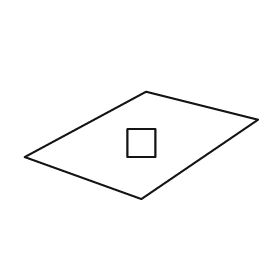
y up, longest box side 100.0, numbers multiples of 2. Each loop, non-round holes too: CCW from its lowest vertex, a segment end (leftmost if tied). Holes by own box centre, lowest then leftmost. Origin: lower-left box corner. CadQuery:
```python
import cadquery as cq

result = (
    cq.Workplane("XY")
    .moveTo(50.0, 0.0)
    .lineTo(100.0, 34.0)
    .lineTo(52.0, 46.0)
    .lineTo(0.0, 18.0)
    .close()
    .moveTo(44.0, 18.0)
    .lineTo(56.0, 18.0)
    .lineTo(56.0, 30.0)
    .lineTo(44.0, 30.0)
    .close()
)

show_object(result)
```